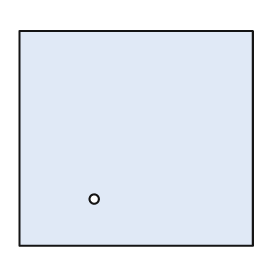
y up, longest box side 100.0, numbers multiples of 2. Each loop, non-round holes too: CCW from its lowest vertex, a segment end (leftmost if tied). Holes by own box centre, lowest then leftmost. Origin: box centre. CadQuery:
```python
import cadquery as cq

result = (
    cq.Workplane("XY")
    .moveTo(-50.0, -46.0)
    .lineTo(50.0, -46.0)
    .lineTo(50.0, 46.0)
    .lineTo(-50.0, 46.0)
    .close()
    .moveTo(-18.0, -26.0)
    .circle(2.0)
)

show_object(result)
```